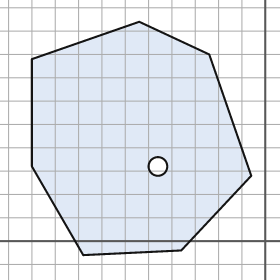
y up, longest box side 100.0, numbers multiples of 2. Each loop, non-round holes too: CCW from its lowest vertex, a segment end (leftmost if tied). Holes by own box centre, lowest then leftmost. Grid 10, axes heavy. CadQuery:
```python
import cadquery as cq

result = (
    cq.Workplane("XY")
    .moveTo(-78.0, -6.0)
    .lineTo(-36.0, -4.0)
    .lineTo(-6.0, 28.0)
    .lineTo(-24.0, 80.0)
    .lineTo(-54.0, 94.0)
    .lineTo(-100.0, 78.0)
    .lineTo(-100.0, 32.0)
    .close()
    .moveTo(-46.0, 32.0)
    .circle(4.0)
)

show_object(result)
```